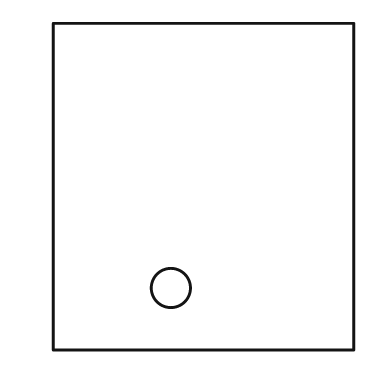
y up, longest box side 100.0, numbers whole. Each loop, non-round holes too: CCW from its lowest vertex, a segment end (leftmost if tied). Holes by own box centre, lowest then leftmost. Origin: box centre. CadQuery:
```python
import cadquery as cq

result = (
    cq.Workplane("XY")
    .moveTo(-46.0, -50.0)
    .lineTo(46.0, -50.0)
    .lineTo(46.0, 50.0)
    .lineTo(-46.0, 50.0)
    .close()
    .moveTo(-10.0, -31.0)
    .circle(6.0)
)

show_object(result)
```